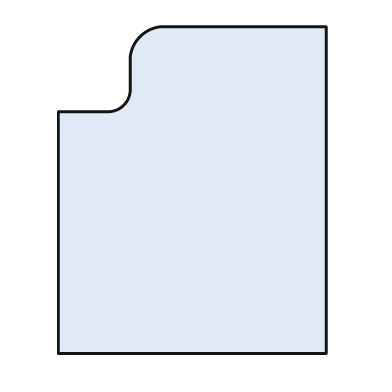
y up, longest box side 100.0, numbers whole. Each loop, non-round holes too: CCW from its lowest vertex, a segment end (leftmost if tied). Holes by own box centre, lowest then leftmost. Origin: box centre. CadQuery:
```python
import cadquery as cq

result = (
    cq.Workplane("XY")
    .moveTo(-41.0, -50.0)
    .lineTo(41.0, -50.0)
    .lineTo(41.0, 50.0)
    .lineTo(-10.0, 50.0)
    .threePointArc((-16.0, 47.0), (-19.0, 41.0))
    .lineTo(-19.0, 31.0)
    .threePointArc((-21.0, 26.0), (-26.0, 24.0))
    .lineTo(-41.0, 24.0)
    .close()
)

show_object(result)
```